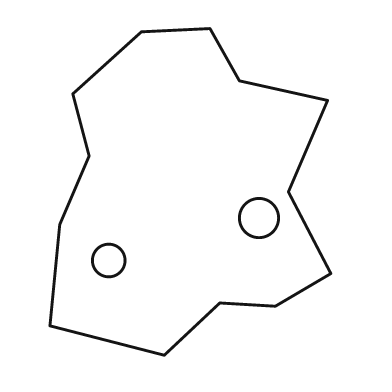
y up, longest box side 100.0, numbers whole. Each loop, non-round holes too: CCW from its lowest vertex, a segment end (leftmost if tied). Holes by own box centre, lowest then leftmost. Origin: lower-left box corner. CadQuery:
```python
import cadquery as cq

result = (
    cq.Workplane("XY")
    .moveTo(35.0, 0.0)
    .lineTo(52.0, 16.0)
    .lineTo(69.0, 15.0)
    .lineTo(86.0, 25.0)
    .lineTo(73.0, 50.0)
    .lineTo(85.0, 78.0)
    .lineTo(58.0, 84.0)
    .lineTo(49.0, 100.0)
    .lineTo(28.0, 99.0)
    .lineTo(7.0, 80.0)
    .lineTo(12.0, 61.0)
    .lineTo(3.0, 40.0)
    .lineTo(0.0, 9.0)
    .close()
    .moveTo(18.0, 29.0)
    .circle(5.0)
    .moveTo(64.0, 42.0)
    .circle(6.0)
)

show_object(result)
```